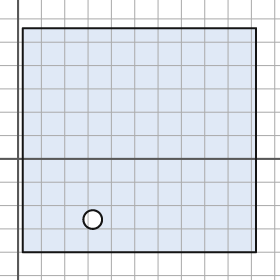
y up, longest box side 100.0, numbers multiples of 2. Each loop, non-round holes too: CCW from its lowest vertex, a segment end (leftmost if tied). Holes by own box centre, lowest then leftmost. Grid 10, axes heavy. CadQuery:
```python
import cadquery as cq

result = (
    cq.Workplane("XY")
    .moveTo(2.0, -40.0)
    .lineTo(102.0, -40.0)
    .lineTo(102.0, 56.0)
    .lineTo(2.0, 56.0)
    .close()
    .moveTo(32.0, -26.0)
    .circle(4.0)
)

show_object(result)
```